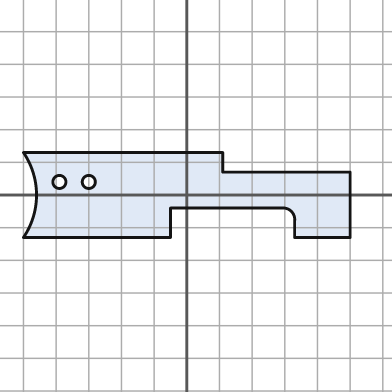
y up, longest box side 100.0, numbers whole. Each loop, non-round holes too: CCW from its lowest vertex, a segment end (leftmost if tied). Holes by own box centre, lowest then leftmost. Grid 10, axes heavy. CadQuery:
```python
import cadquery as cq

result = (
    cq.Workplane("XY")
    .moveTo(-50.0, -13.0)
    .lineTo(-5.0, -13.0)
    .lineTo(-5.0, -4.0)
    .lineTo(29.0, -4.0)
    .threePointArc((32.0, -5.0), (33.0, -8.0))
    .lineTo(33.0, -13.0)
    .lineTo(50.0, -13.0)
    .lineTo(50.0, 7.0)
    .lineTo(11.0, 7.0)
    .lineTo(11.0, 13.0)
    .lineTo(-50.0, 13.0)
    .threePointArc((-46.0, 0.0), (-50.0, -13.0))
    .close()
    .moveTo(-39.0, 4.0)
    .circle(2.0)
    .moveTo(-30.0, 4.0)
    .circle(2.0)
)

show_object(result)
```